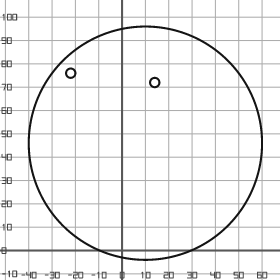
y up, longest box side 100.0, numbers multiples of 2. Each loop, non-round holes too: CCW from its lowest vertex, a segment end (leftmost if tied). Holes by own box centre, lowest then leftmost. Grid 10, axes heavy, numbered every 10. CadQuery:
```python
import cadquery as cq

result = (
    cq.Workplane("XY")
    .moveTo(10.0, 46.0)
    .circle(50.0)
    .moveTo(14.0, 72.0)
    .circle(2.0)
    .moveTo(-22.0, 76.0)
    .circle(2.0)
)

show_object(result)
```